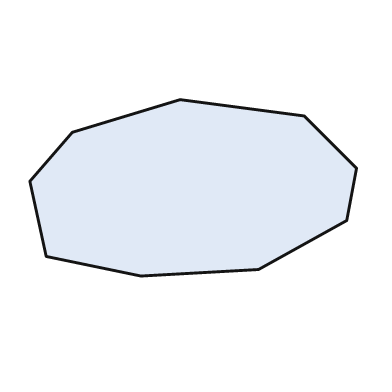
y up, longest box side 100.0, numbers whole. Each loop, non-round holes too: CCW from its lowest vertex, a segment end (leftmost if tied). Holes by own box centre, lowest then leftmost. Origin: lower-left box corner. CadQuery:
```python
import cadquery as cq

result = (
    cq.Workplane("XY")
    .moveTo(34.0, 0.0)
    .lineTo(70.0, 2.0)
    .lineTo(97.0, 17.0)
    .lineTo(100.0, 33.0)
    .lineTo(84.0, 49.0)
    .lineTo(46.0, 54.0)
    .lineTo(13.0, 44.0)
    .lineTo(0.0, 29.0)
    .lineTo(5.0, 6.0)
    .close()
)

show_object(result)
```